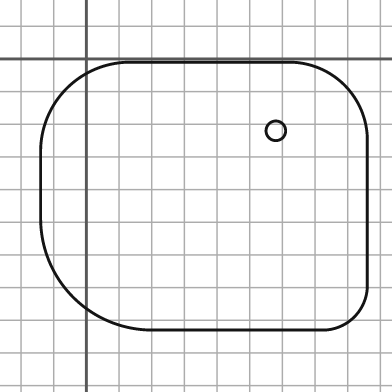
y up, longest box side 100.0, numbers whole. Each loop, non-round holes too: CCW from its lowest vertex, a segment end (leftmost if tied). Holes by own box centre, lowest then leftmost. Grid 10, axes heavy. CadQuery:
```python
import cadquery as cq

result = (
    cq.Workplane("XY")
    .moveTo(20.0, -83.0)
    .lineTo(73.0, -83.0)
    .threePointArc((82.0, -79.0), (86.0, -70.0))
    .lineTo(86.0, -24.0)
    .threePointArc((79.0, -8.0), (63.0, -1.0))
    .lineTo(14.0, -1.0)
    .threePointArc((-6.0, -9.0), (-14.0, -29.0))
    .lineTo(-14.0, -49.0)
    .threePointArc((-4.0, -73.0), (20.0, -83.0))
    .close()
    .moveTo(58.0, -22.0)
    .circle(3.0)
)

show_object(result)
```